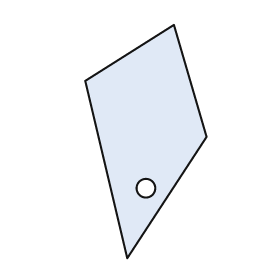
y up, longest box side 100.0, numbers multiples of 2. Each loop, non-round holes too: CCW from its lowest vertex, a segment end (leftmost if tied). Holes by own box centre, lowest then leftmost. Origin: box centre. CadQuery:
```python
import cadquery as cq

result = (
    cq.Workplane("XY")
    .moveTo(-8.0, -50.0)
    .lineTo(26.0, 2.0)
    .lineTo(12.0, 50.0)
    .lineTo(-26.0, 26.0)
    .close()
    .moveTo(0.0, -20.0)
    .circle(4.0)
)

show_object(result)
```